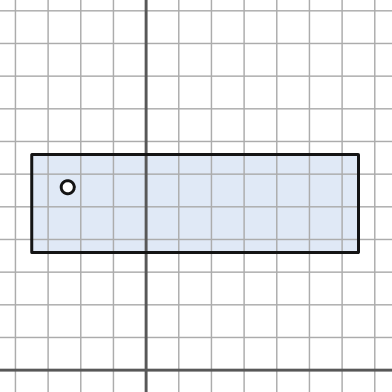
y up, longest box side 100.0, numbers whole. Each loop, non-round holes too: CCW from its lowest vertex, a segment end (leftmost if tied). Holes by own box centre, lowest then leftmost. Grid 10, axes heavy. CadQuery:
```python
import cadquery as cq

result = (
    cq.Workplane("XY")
    .moveTo(-35.0, 36.0)
    .lineTo(65.0, 36.0)
    .lineTo(65.0, 66.0)
    .lineTo(-35.0, 66.0)
    .close()
    .moveTo(-24.0, 56.0)
    .circle(2.0)
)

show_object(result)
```